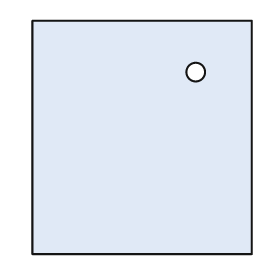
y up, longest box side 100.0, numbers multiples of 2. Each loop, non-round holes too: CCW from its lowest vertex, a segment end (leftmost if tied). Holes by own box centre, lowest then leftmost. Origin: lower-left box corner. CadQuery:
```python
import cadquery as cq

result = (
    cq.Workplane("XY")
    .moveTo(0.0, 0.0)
    .lineTo(94.0, 0.0)
    .lineTo(94.0, 100.0)
    .lineTo(0.0, 100.0)
    .close()
    .moveTo(70.0, 78.0)
    .circle(4.0)
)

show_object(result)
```